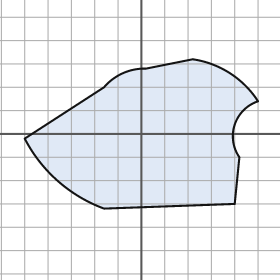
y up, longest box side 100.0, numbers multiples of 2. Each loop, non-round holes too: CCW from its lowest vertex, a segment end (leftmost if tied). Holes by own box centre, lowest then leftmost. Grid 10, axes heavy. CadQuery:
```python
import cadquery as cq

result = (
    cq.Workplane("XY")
    .moveTo(-16.0, -32.0)
    .lineTo(40.0, -30.0)
    .lineTo(42.0, -10.0)
    .threePointArc((40.0, 4.0), (50.0, 14.0))
    .threePointArc((38.0, 26.0), (22.0, 32.0))
    .lineTo(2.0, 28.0)
    .threePointArc((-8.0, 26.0), (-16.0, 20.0))
    .lineTo(-50.0, -2.0)
    .threePointArc((-36.0, -20.0), (-16.0, -32.0))
    .close()
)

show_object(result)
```